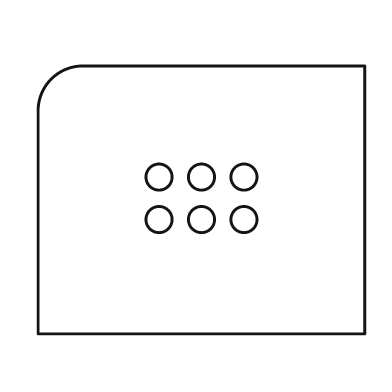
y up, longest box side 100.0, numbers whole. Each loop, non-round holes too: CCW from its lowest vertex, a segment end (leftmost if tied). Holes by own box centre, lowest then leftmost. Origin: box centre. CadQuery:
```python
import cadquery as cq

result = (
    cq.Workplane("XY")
    .moveTo(-50.0, -41.0)
    .lineTo(50.0, -41.0)
    .lineTo(50.0, 41.0)
    .lineTo(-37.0, 41.0)
    .threePointArc((-46.0, 37.0), (-50.0, 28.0))
    .close()
    .moveTo(-13.0, -6.0)
    .circle(4.0)
    .moveTo(0.0, -6.0)
    .circle(4.0)
    .moveTo(13.0, -6.0)
    .circle(4.0)
    .moveTo(-13.0, 7.0)
    .circle(4.0)
    .moveTo(0.0, 7.0)
    .circle(4.0)
    .moveTo(13.0, 7.0)
    .circle(4.0)
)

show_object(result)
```